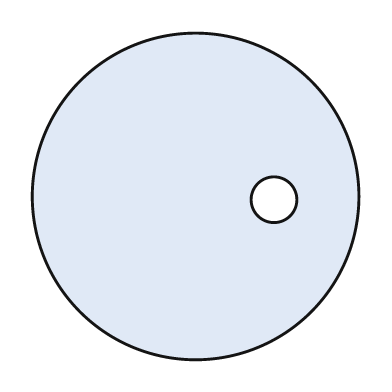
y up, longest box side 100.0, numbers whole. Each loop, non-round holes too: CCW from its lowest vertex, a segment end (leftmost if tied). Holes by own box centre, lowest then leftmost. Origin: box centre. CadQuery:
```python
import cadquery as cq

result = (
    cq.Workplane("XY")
    .moveTo(0.0, 0.0)
    .circle(50.0)
    .moveTo(24.0, -1.0)
    .circle(7.0)
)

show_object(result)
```